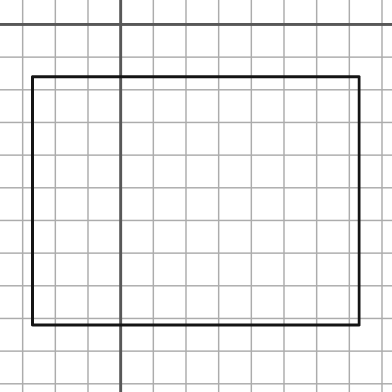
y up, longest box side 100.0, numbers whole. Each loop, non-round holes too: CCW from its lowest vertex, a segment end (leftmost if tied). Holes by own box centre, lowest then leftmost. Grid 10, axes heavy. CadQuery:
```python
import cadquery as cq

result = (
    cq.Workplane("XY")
    .moveTo(-27.0, -92.0)
    .lineTo(73.0, -92.0)
    .lineTo(73.0, -16.0)
    .lineTo(-27.0, -16.0)
    .close()
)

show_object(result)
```